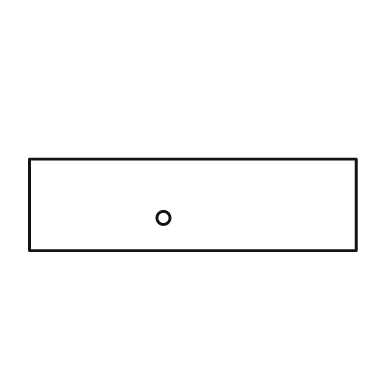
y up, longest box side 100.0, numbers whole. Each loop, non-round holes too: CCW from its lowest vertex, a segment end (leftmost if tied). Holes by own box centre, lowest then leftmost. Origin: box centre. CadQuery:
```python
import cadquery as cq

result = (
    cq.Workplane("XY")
    .moveTo(-50.0, -14.0)
    .lineTo(50.0, -14.0)
    .lineTo(50.0, 14.0)
    .lineTo(-50.0, 14.0)
    .close()
    .moveTo(-9.0, -4.0)
    .circle(2.0)
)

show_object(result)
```